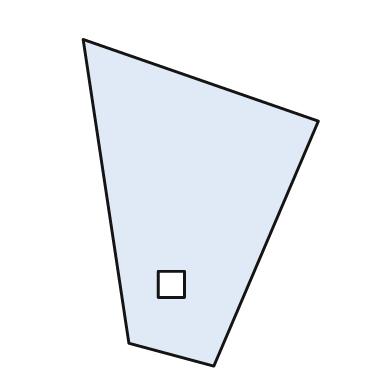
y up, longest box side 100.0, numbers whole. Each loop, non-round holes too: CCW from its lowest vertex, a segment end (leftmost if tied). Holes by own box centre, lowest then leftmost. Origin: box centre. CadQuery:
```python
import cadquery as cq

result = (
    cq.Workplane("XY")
    .moveTo(4.0, -50.0)
    .lineTo(36.0, 25.0)
    .lineTo(-36.0, 50.0)
    .lineTo(-22.0, -43.0)
    .close()
    .moveTo(-13.0, -29.0)
    .lineTo(-5.0, -29.0)
    .lineTo(-5.0, -21.0)
    .lineTo(-13.0, -21.0)
    .close()
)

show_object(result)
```